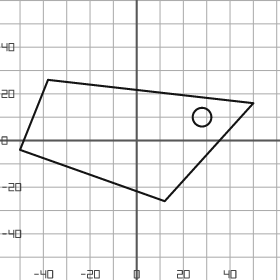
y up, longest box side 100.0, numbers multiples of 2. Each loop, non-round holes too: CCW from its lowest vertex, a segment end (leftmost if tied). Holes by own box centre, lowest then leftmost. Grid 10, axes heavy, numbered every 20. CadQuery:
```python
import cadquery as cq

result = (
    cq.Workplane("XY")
    .moveTo(12.0, -26.0)
    .lineTo(50.0, 16.0)
    .lineTo(-38.0, 26.0)
    .lineTo(-50.0, -4.0)
    .close()
    .moveTo(28.0, 10.0)
    .circle(4.0)
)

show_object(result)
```